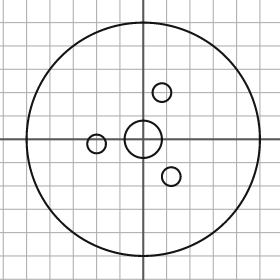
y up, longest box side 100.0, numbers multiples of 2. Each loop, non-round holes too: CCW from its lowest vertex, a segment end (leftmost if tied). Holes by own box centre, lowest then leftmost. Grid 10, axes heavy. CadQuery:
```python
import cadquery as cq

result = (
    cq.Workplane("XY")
    .moveTo(0.0, 0.0)
    .circle(50.0)
    .moveTo(12.0, -16.0)
    .circle(4.0)
    .moveTo(-20.0, -2.0)
    .circle(4.0)
    .moveTo(0.0, 0.0)
    .circle(8.0)
    .moveTo(8.0, 20.0)
    .circle(4.0)
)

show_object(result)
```